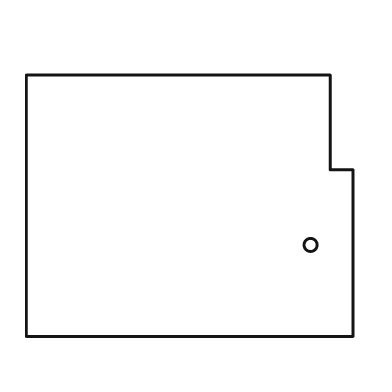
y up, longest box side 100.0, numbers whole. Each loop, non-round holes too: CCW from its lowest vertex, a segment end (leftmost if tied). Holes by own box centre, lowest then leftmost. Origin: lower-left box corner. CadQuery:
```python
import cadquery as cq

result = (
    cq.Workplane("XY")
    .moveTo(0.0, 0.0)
    .lineTo(100.0, 0.0)
    .lineTo(100.0, 51.0)
    .lineTo(93.0, 51.0)
    .lineTo(93.0, 80.0)
    .lineTo(0.0, 80.0)
    .close()
    .moveTo(87.0, 28.0)
    .circle(2.0)
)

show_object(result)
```